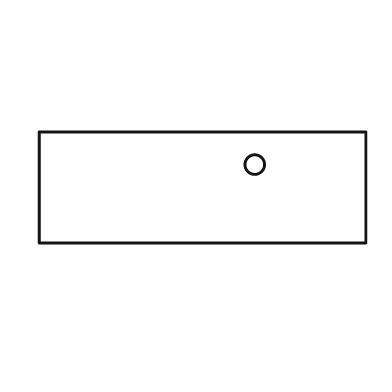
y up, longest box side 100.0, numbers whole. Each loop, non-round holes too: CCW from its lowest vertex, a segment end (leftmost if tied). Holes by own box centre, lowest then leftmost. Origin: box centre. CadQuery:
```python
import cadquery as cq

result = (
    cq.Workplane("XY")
    .moveTo(-50.0, -17.0)
    .lineTo(50.0, -17.0)
    .lineTo(50.0, 17.0)
    .lineTo(-50.0, 17.0)
    .close()
    .moveTo(16.0, 7.0)
    .circle(3.0)
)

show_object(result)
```